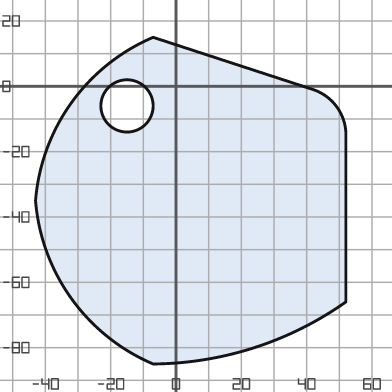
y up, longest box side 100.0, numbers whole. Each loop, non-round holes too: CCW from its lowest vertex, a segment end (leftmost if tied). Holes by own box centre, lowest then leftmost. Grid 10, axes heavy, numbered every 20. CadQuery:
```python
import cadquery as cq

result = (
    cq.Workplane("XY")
    .moveTo(-7.0, -85.0)
    .threePointArc((24.0, -80.0), (52.0, -66.0))
    .lineTo(52.0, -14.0)
    .threePointArc((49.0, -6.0), (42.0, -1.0))
    .lineTo(-7.0, 15.0)
    .threePointArc((-32.0, -5.0), (-43.0, -35.0))
    .threePointArc((-32.0, -65.0), (-7.0, -85.0))
    .close()
    .moveTo(-15.0, -6.0)
    .circle(8.0)
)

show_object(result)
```